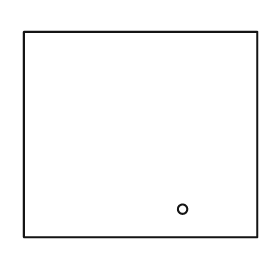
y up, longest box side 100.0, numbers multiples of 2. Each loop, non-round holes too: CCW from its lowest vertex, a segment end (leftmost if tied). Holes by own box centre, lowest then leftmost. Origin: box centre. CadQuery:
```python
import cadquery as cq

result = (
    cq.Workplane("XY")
    .moveTo(-50.0, -44.0)
    .lineTo(50.0, -44.0)
    .lineTo(50.0, 44.0)
    .lineTo(-50.0, 44.0)
    .close()
    .moveTo(18.0, -32.0)
    .circle(2.0)
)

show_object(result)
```